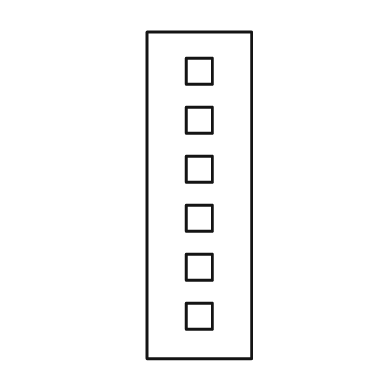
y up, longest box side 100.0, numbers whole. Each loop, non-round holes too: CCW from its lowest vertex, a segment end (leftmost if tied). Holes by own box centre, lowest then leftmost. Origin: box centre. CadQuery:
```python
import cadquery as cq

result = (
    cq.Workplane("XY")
    .moveTo(-16.0, -50.0)
    .lineTo(16.0, -50.0)
    .lineTo(16.0, 50.0)
    .lineTo(-16.0, 50.0)
    .close()
    .moveTo(-4.0, -41.0)
    .lineTo(4.0, -41.0)
    .lineTo(4.0, -33.0)
    .lineTo(-4.0, -33.0)
    .close()
    .moveTo(-4.0, -26.0)
    .lineTo(4.0, -26.0)
    .lineTo(4.0, -18.0)
    .lineTo(-4.0, -18.0)
    .close()
    .moveTo(-4.0, -11.0)
    .lineTo(4.0, -11.0)
    .lineTo(4.0, -3.0)
    .lineTo(-4.0, -3.0)
    .close()
    .moveTo(-4.0, 4.0)
    .lineTo(4.0, 4.0)
    .lineTo(4.0, 12.0)
    .lineTo(-4.0, 12.0)
    .close()
    .moveTo(-4.0, 19.0)
    .lineTo(4.0, 19.0)
    .lineTo(4.0, 27.0)
    .lineTo(-4.0, 27.0)
    .close()
    .moveTo(-4.0, 34.0)
    .lineTo(4.0, 34.0)
    .lineTo(4.0, 42.0)
    .lineTo(-4.0, 42.0)
    .close()
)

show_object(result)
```